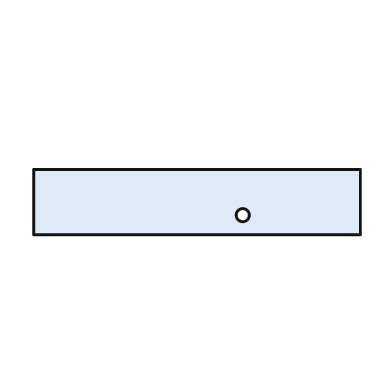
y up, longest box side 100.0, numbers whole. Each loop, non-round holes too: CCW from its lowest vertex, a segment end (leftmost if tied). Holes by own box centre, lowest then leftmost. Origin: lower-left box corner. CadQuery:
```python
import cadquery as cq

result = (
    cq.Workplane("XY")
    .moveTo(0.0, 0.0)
    .lineTo(100.0, 0.0)
    .lineTo(100.0, 20.0)
    .lineTo(0.0, 20.0)
    .close()
    .moveTo(64.0, 6.0)
    .circle(2.0)
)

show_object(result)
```